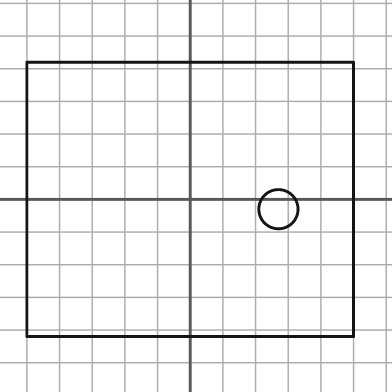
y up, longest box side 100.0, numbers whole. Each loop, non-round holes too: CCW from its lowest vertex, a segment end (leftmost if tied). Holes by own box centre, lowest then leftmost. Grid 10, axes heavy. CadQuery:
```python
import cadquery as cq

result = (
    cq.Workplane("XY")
    .moveTo(-50.0, -42.0)
    .lineTo(50.0, -42.0)
    .lineTo(50.0, 42.0)
    .lineTo(-50.0, 42.0)
    .close()
    .moveTo(27.0, -3.0)
    .circle(6.0)
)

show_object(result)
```